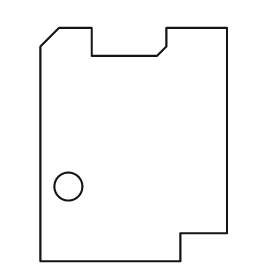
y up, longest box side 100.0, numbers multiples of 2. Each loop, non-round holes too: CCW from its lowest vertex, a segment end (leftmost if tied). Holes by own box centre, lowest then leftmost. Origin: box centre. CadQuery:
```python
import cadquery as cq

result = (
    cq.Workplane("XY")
    .moveTo(-40.0, -50.0)
    .lineTo(20.0, -50.0)
    .lineTo(20.0, -38.0)
    .lineTo(40.0, -38.0)
    .lineTo(40.0, 50.0)
    .lineTo(14.0, 50.0)
    .lineTo(14.0, 42.0)
    .lineTo(10.0, 38.0)
    .lineTo(-18.0, 38.0)
    .lineTo(-18.0, 50.0)
    .lineTo(-32.0, 50.0)
    .lineTo(-40.0, 42.0)
    .close()
    .moveTo(-28.0, -18.0)
    .circle(6.0)
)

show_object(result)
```